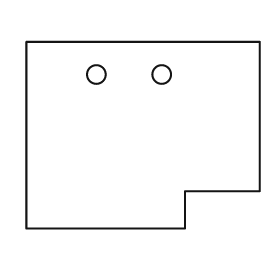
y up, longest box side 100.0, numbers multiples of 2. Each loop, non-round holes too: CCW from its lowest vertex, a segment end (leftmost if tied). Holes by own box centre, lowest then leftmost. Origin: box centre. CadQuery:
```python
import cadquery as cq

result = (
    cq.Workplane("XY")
    .moveTo(-50.0, -40.0)
    .lineTo(18.0, -40.0)
    .lineTo(18.0, -24.0)
    .lineTo(50.0, -24.0)
    .lineTo(50.0, 40.0)
    .lineTo(-50.0, 40.0)
    .close()
    .moveTo(-20.0, 26.0)
    .circle(4.0)
    .moveTo(8.0, 26.0)
    .circle(4.0)
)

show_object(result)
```